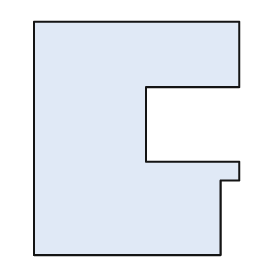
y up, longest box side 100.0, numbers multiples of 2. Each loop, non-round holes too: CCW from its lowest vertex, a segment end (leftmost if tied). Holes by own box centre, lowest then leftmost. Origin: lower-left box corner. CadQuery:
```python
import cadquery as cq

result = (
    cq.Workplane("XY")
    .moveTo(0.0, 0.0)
    .lineTo(80.0, 0.0)
    .lineTo(80.0, 32.0)
    .lineTo(88.0, 32.0)
    .lineTo(88.0, 40.0)
    .lineTo(48.0, 40.0)
    .lineTo(48.0, 72.0)
    .lineTo(88.0, 72.0)
    .lineTo(88.0, 100.0)
    .lineTo(0.0, 100.0)
    .close()
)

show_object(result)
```